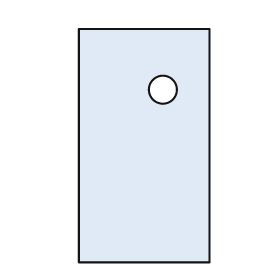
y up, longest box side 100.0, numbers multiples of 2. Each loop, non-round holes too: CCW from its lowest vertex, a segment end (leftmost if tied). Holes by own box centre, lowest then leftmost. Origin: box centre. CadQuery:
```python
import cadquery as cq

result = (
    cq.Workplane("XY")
    .moveTo(-28.0, -50.0)
    .lineTo(28.0, -50.0)
    .lineTo(28.0, 50.0)
    .lineTo(-28.0, 50.0)
    .close()
    .moveTo(8.0, 24.0)
    .circle(6.0)
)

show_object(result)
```